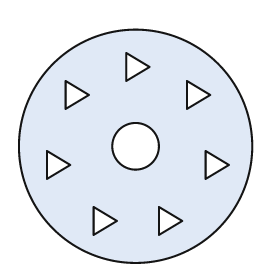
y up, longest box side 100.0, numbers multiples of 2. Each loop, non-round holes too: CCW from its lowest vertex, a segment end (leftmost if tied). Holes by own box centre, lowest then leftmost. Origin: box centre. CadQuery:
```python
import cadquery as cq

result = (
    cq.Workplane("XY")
    .moveTo(0.0, 0.0)
    .circle(50.0)
    .moveTo(-18.0, -38.0)
    .lineTo(-8.0, -32.0)
    .lineTo(-18.0, -26.0)
    .close()
    .moveTo(10.0, -38.0)
    .lineTo(20.0, -32.0)
    .lineTo(10.0, -26.0)
    .close()
    .moveTo(-38.0, -14.0)
    .lineTo(-28.0, -8.0)
    .lineTo(-38.0, -2.0)
    .close()
    .moveTo(30.0, -14.0)
    .lineTo(40.0, -8.0)
    .lineTo(30.0, -2.0)
    .close()
    .moveTo(0.0, 0.0)
    .circle(10.0)
    .moveTo(-30.0, 16.0)
    .lineTo(-20.0, 22.0)
    .lineTo(-30.0, 28.0)
    .close()
    .moveTo(22.0, 16.0)
    .lineTo(32.0, 22.0)
    .lineTo(22.0, 28.0)
    .close()
    .moveTo(-4.0, 28.0)
    .lineTo(6.0, 34.0)
    .lineTo(-4.0, 40.0)
    .close()
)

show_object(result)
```